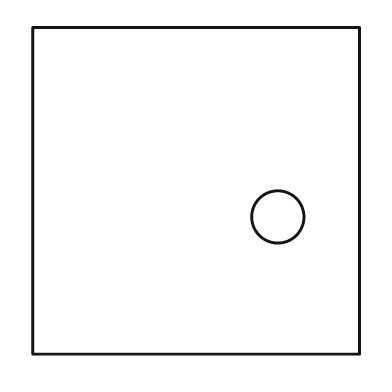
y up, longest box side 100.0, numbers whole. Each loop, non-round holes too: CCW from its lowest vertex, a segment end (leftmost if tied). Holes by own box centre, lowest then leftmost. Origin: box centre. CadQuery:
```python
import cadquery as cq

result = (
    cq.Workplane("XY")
    .moveTo(-50.0, -50.0)
    .lineTo(50.0, -50.0)
    .lineTo(50.0, 50.0)
    .lineTo(-50.0, 50.0)
    .close()
    .moveTo(25.0, -8.0)
    .circle(8.0)
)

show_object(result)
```